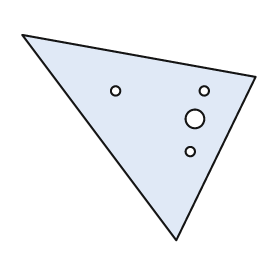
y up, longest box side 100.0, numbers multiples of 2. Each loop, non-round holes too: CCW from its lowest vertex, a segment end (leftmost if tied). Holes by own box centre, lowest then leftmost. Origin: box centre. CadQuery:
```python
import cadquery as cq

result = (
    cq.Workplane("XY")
    .moveTo(16.0, -44.0)
    .lineTo(50.0, 26.0)
    .lineTo(-50.0, 44.0)
    .close()
    .moveTo(22.0, -6.0)
    .circle(2.0)
    .moveTo(24.0, 8.0)
    .circle(4.0)
    .moveTo(-10.0, 20.0)
    .circle(2.0)
    .moveTo(28.0, 20.0)
    .circle(2.0)
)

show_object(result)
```